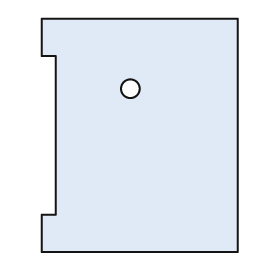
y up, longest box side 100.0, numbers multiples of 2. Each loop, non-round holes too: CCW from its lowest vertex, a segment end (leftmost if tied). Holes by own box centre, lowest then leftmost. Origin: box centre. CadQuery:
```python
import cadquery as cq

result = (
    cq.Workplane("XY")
    .moveTo(-42.0, -50.0)
    .lineTo(42.0, -50.0)
    .lineTo(42.0, 50.0)
    .lineTo(-42.0, 50.0)
    .lineTo(-42.0, 34.0)
    .lineTo(-36.0, 34.0)
    .lineTo(-36.0, -34.0)
    .lineTo(-42.0, -34.0)
    .close()
    .moveTo(-4.0, 20.0)
    .circle(4.0)
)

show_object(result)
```